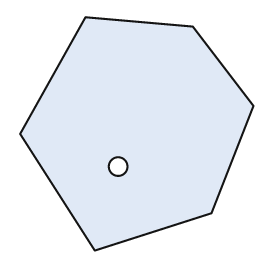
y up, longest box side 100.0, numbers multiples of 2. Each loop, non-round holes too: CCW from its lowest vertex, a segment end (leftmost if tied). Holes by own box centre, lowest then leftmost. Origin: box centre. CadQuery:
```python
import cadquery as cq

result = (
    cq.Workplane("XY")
    .moveTo(-18.0, -50.0)
    .lineTo(32.0, -34.0)
    .lineTo(50.0, 12.0)
    .lineTo(24.0, 46.0)
    .lineTo(-22.0, 50.0)
    .lineTo(-50.0, 0.0)
    .close()
    .moveTo(-8.0, -14.0)
    .circle(4.0)
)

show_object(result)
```